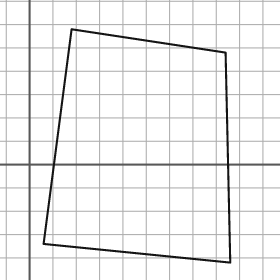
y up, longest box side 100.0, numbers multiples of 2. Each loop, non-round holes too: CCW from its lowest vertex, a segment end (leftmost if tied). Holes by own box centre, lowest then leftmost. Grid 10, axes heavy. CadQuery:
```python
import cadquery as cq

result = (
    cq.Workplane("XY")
    .moveTo(86.0, -42.0)
    .lineTo(84.0, 48.0)
    .lineTo(18.0, 58.0)
    .lineTo(6.0, -34.0)
    .close()
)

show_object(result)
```